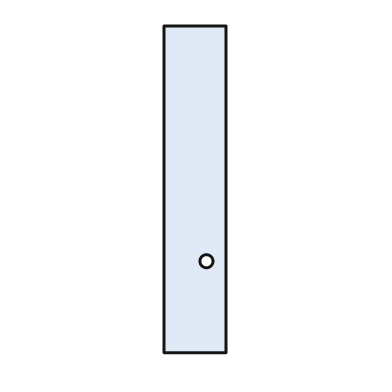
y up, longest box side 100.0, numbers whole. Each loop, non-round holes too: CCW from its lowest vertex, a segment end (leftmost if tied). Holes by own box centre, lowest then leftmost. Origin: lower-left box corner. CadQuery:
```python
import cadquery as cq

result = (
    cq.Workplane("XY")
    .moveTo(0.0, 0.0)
    .lineTo(19.0, 0.0)
    .lineTo(19.0, 100.0)
    .lineTo(0.0, 100.0)
    .close()
    .moveTo(13.0, 28.0)
    .circle(2.0)
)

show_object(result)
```